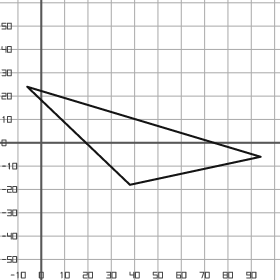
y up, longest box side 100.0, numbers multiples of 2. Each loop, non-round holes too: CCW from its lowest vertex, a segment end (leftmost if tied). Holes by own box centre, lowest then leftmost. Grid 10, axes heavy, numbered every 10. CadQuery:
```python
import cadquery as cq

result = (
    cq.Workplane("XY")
    .moveTo(38.0, -18.0)
    .lineTo(94.0, -6.0)
    .lineTo(-6.0, 24.0)
    .close()
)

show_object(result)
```